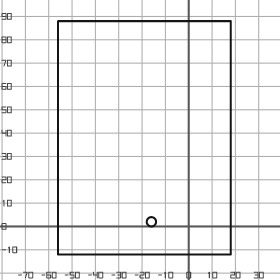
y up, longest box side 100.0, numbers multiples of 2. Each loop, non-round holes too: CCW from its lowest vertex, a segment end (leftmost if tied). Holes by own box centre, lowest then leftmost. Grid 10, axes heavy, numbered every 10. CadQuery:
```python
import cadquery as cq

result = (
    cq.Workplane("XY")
    .moveTo(-56.0, -12.0)
    .lineTo(18.0, -12.0)
    .lineTo(18.0, 88.0)
    .lineTo(-56.0, 88.0)
    .close()
    .moveTo(-16.0, 2.0)
    .circle(2.0)
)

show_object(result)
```